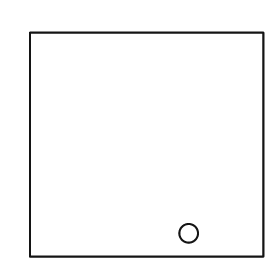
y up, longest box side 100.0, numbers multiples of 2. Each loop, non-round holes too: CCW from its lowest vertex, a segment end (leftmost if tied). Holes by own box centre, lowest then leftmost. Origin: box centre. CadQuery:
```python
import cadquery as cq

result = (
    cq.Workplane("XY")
    .moveTo(-50.0, -48.0)
    .lineTo(50.0, -48.0)
    .lineTo(50.0, 48.0)
    .lineTo(-50.0, 48.0)
    .close()
    .moveTo(18.0, -38.0)
    .circle(4.0)
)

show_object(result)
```